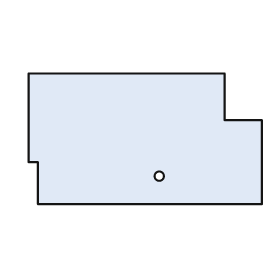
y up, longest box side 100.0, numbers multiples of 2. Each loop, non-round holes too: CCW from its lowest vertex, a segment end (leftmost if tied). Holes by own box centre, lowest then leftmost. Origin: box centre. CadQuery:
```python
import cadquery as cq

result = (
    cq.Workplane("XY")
    .moveTo(-46.0, -28.0)
    .lineTo(50.0, -28.0)
    .lineTo(50.0, 8.0)
    .lineTo(34.0, 8.0)
    .lineTo(34.0, 28.0)
    .lineTo(-50.0, 28.0)
    .lineTo(-50.0, -10.0)
    .lineTo(-46.0, -10.0)
    .close()
    .moveTo(6.0, -16.0)
    .circle(2.0)
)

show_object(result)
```